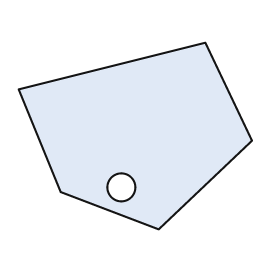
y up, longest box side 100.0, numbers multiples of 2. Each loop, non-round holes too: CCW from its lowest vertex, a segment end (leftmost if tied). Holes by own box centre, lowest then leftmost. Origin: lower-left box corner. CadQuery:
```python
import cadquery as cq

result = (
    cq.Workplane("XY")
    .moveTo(60.0, 0.0)
    .lineTo(100.0, 38.0)
    .lineTo(80.0, 80.0)
    .lineTo(0.0, 60.0)
    .lineTo(18.0, 16.0)
    .close()
    .moveTo(44.0, 18.0)
    .circle(6.0)
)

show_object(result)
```